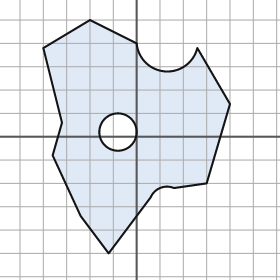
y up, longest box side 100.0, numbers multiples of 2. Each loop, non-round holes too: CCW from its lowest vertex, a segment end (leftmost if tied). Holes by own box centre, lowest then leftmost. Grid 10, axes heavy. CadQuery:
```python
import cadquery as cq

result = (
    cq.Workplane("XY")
    .moveTo(-12.0, -50.0)
    .lineTo(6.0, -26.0)
    .threePointArc((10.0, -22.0), (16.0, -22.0))
    .lineTo(30.0, -20.0)
    .lineTo(40.0, 14.0)
    .lineTo(26.0, 38.0)
    .threePointArc((12.0, 28.0), (0.0, 40.0))
    .lineTo(-20.0, 50.0)
    .lineTo(-40.0, 38.0)
    .lineTo(-32.0, 6.0)
    .lineTo(-36.0, -8.0)
    .lineTo(-24.0, -34.0)
    .close()
    .moveTo(-8.0, 2.0)
    .circle(8.0)
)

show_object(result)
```